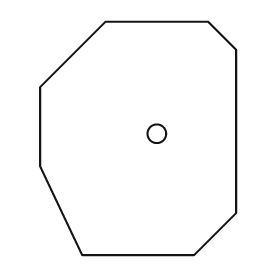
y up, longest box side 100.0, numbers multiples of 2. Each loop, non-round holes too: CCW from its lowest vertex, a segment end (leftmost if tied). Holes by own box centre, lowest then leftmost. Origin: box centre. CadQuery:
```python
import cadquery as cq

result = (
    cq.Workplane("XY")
    .moveTo(-24.0, -50.0)
    .lineTo(24.0, -50.0)
    .lineTo(42.0, -32.0)
    .lineTo(42.0, 38.0)
    .lineTo(30.0, 50.0)
    .lineTo(-14.0, 50.0)
    .lineTo(-42.0, 22.0)
    .lineTo(-42.0, -12.0)
    .close()
    .moveTo(8.0, 2.0)
    .circle(4.0)
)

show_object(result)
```